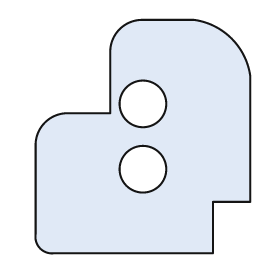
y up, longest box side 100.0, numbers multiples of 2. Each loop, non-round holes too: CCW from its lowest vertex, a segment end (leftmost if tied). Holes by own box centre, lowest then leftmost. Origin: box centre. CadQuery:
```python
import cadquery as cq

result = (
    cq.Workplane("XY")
    .moveTo(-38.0, -50.0)
    .lineTo(30.0, -50.0)
    .lineTo(30.0, -28.0)
    .lineTo(46.0, -28.0)
    .lineTo(46.0, 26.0)
    .threePointArc((38.0, 42.0), (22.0, 50.0))
    .lineTo(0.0, 50.0)
    .threePointArc((-10.0, 46.0), (-14.0, 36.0))
    .lineTo(-14.0, 10.0)
    .lineTo(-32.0, 10.0)
    .threePointArc((-42.0, 6.0), (-46.0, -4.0))
    .lineTo(-46.0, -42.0)
    .threePointArc((-44.0, -48.0), (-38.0, -50.0))
    .close()
    .moveTo(0.0, -14.0)
    .circle(10.0)
    .moveTo(0.0, 14.0)
    .circle(10.0)
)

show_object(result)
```